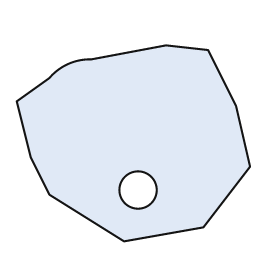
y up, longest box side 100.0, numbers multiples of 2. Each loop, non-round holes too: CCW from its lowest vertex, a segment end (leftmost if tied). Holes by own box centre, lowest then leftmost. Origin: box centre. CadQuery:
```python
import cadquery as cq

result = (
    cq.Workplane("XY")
    .moveTo(-4.0, -42.0)
    .lineTo(30.0, -36.0)
    .lineTo(50.0, -10.0)
    .lineTo(44.0, 16.0)
    .lineTo(32.0, 40.0)
    .lineTo(14.0, 42.0)
    .lineTo(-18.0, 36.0)
    .threePointArc((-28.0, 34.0), (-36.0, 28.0))
    .lineTo(-50.0, 18.0)
    .lineTo(-44.0, -6.0)
    .lineTo(-36.0, -22.0)
    .close()
    .moveTo(2.0, -20.0)
    .circle(8.0)
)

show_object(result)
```